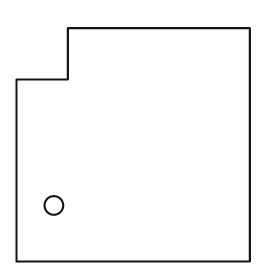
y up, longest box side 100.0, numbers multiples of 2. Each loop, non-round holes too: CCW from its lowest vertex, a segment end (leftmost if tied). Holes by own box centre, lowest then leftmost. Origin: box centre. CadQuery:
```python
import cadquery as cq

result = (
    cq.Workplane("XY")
    .moveTo(-50.0, -50.0)
    .lineTo(50.0, -50.0)
    .lineTo(50.0, 50.0)
    .lineTo(-28.0, 50.0)
    .lineTo(-28.0, 28.0)
    .lineTo(-50.0, 28.0)
    .close()
    .moveTo(-34.0, -26.0)
    .circle(4.0)
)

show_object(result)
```